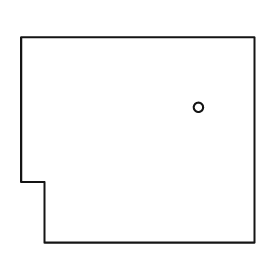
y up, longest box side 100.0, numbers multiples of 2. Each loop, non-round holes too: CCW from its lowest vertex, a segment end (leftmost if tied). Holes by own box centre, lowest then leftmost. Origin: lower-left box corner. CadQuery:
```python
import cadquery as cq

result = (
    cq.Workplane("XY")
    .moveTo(10.0, 0.0)
    .lineTo(100.0, 0.0)
    .lineTo(100.0, 88.0)
    .lineTo(0.0, 88.0)
    .lineTo(0.0, 26.0)
    .lineTo(10.0, 26.0)
    .close()
    .moveTo(76.0, 58.0)
    .circle(2.0)
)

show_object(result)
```